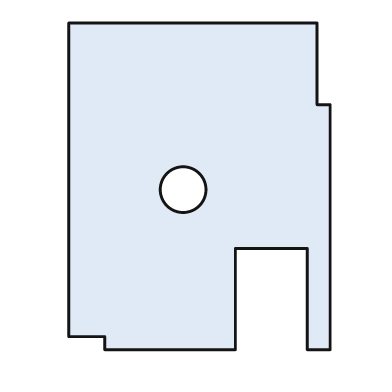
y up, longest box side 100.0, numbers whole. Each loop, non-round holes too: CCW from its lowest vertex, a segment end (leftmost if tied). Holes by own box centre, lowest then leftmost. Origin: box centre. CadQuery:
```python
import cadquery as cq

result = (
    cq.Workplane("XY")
    .moveTo(-29.0, -50.0)
    .lineTo(11.0, -50.0)
    .lineTo(11.0, -19.0)
    .lineTo(33.0, -19.0)
    .lineTo(33.0, -50.0)
    .lineTo(40.0, -50.0)
    .lineTo(40.0, 25.0)
    .lineTo(36.0, 25.0)
    .lineTo(36.0, 50.0)
    .lineTo(-40.0, 50.0)
    .lineTo(-40.0, -46.0)
    .lineTo(-29.0, -46.0)
    .close()
    .moveTo(-5.0, -1.0)
    .circle(7.0)
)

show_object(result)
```